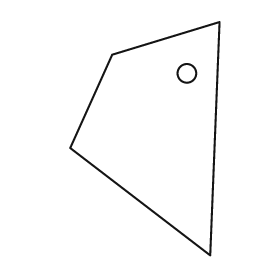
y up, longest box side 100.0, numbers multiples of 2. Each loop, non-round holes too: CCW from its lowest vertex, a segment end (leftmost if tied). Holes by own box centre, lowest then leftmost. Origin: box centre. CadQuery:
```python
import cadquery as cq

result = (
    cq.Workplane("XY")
    .moveTo(28.0, -50.0)
    .lineTo(32.0, 50.0)
    .lineTo(-14.0, 36.0)
    .lineTo(-32.0, -4.0)
    .close()
    .moveTo(18.0, 28.0)
    .circle(4.0)
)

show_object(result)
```